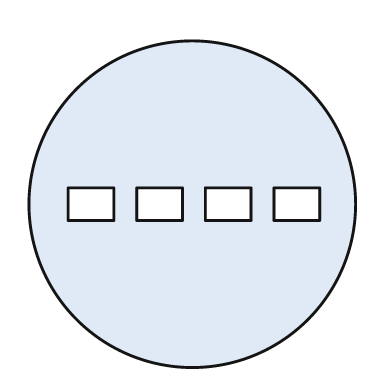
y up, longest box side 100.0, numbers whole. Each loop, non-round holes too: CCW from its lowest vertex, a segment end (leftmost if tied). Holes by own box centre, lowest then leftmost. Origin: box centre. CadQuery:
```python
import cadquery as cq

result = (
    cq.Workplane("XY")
    .moveTo(0.0, 0.0)
    .circle(50.0)
    .moveTo(-38.0, -5.0)
    .lineTo(-24.0, -5.0)
    .lineTo(-24.0, 5.0)
    .lineTo(-38.0, 5.0)
    .close()
    .moveTo(-17.0, -5.0)
    .lineTo(-3.0, -5.0)
    .lineTo(-3.0, 5.0)
    .lineTo(-17.0, 5.0)
    .close()
    .moveTo(4.0, -5.0)
    .lineTo(18.0, -5.0)
    .lineTo(18.0, 5.0)
    .lineTo(4.0, 5.0)
    .close()
    .moveTo(25.0, -5.0)
    .lineTo(39.0, -5.0)
    .lineTo(39.0, 5.0)
    .lineTo(25.0, 5.0)
    .close()
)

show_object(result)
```